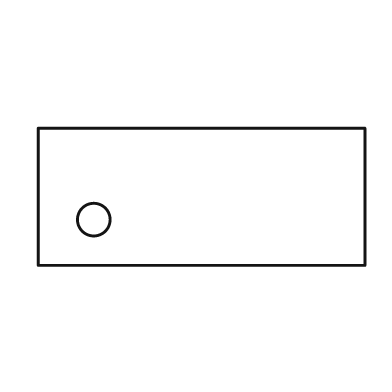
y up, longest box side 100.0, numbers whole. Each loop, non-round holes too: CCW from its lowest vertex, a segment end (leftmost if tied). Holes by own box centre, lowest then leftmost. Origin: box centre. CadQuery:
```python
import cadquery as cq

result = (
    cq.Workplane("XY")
    .moveTo(-50.0, -21.0)
    .lineTo(50.0, -21.0)
    .lineTo(50.0, 21.0)
    .lineTo(-50.0, 21.0)
    .close()
    .moveTo(-33.0, -7.0)
    .circle(5.0)
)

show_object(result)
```